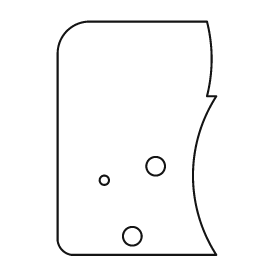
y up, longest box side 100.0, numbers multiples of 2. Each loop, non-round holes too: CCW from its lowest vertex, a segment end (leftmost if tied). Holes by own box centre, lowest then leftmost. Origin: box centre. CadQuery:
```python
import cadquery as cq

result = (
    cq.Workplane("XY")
    .moveTo(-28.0, -50.0)
    .lineTo(34.0, -50.0)
    .threePointArc((24.0, -16.0), (34.0, 18.0))
    .lineTo(30.0, 18.0)
    .threePointArc((32.0, 34.0), (30.0, 50.0))
    .lineTo(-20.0, 50.0)
    .threePointArc((-30.0, 46.0), (-34.0, 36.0))
    .lineTo(-34.0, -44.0)
    .threePointArc((-32.0, -48.0), (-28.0, -50.0))
    .close()
    .moveTo(-2.0, -42.0)
    .circle(4.0)
    .moveTo(-14.0, -18.0)
    .circle(2.0)
    .moveTo(8.0, -12.0)
    .circle(4.0)
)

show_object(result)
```